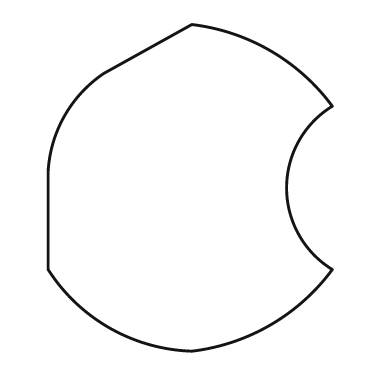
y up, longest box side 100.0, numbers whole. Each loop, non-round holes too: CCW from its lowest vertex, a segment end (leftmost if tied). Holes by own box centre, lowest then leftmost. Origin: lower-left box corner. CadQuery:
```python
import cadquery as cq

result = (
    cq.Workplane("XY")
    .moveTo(44.0, 0.0)
    .threePointArc((68.0, 8.0), (87.0, 25.0))
    .threePointArc((73.0, 50.0), (87.0, 75.0))
    .threePointArc((68.0, 92.0), (44.0, 100.0))
    .lineTo(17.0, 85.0)
    .threePointArc((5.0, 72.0), (0.0, 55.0))
    .lineTo(0.0, 25.0)
    .threePointArc((19.0, 7.0), (44.0, 0.0))
    .close()
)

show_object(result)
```